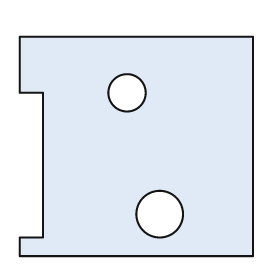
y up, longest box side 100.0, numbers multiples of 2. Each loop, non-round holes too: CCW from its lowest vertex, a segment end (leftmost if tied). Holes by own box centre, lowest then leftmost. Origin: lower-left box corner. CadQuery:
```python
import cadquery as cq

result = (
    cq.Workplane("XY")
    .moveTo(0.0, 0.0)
    .lineTo(100.0, 0.0)
    .lineTo(100.0, 94.0)
    .lineTo(0.0, 94.0)
    .lineTo(0.0, 70.0)
    .lineTo(10.0, 70.0)
    .lineTo(10.0, 8.0)
    .lineTo(0.0, 8.0)
    .close()
    .moveTo(60.0, 18.0)
    .circle(10.0)
    .moveTo(46.0, 70.0)
    .circle(8.0)
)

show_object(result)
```